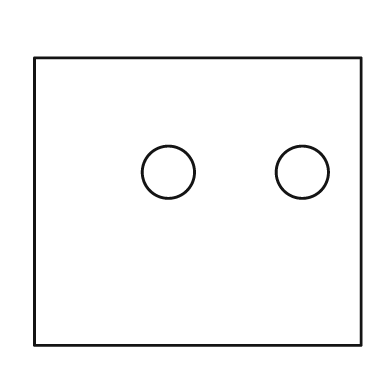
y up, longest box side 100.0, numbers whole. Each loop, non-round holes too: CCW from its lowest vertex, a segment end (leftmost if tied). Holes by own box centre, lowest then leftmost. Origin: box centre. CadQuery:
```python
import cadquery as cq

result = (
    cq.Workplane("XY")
    .moveTo(-50.0, -44.0)
    .lineTo(50.0, -44.0)
    .lineTo(50.0, 44.0)
    .lineTo(-50.0, 44.0)
    .close()
    .moveTo(-9.0, 9.0)
    .circle(8.0)
    .moveTo(32.0, 9.0)
    .circle(8.0)
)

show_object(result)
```